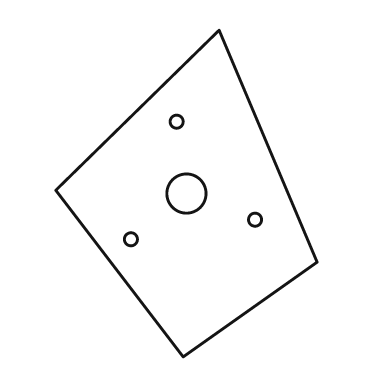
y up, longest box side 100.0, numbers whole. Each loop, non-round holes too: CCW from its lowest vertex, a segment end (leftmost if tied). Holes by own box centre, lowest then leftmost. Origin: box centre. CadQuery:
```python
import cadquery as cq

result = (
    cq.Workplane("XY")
    .moveTo(-1.0, -50.0)
    .lineTo(40.0, -21.0)
    .lineTo(10.0, 50.0)
    .lineTo(-40.0, 1.0)
    .close()
    .moveTo(-17.0, -14.0)
    .circle(2.0)
    .moveTo(21.0, -8.0)
    .circle(2.0)
    .moveTo(0.0, 0.0)
    .circle(6.0)
    .moveTo(-3.0, 22.0)
    .circle(2.0)
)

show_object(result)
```